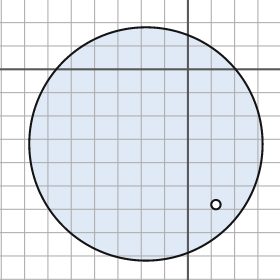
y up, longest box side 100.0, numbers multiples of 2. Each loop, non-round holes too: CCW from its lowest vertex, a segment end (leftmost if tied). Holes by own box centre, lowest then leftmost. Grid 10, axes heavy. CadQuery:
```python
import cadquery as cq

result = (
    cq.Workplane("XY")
    .moveTo(-18.0, -32.0)
    .circle(50.0)
    .moveTo(12.0, -58.0)
    .circle(2.0)
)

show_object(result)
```